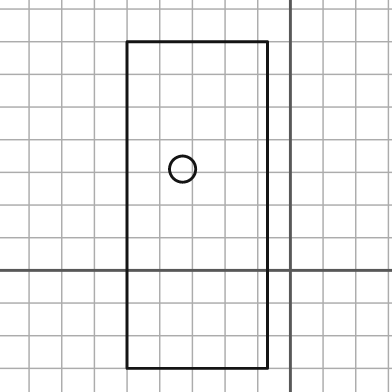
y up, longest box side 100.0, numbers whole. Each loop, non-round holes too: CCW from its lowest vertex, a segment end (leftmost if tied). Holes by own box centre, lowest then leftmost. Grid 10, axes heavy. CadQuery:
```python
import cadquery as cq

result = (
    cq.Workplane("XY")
    .moveTo(-50.0, -30.0)
    .lineTo(-7.0, -30.0)
    .lineTo(-7.0, 70.0)
    .lineTo(-50.0, 70.0)
    .close()
    .moveTo(-33.0, 31.0)
    .circle(4.0)
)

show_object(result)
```